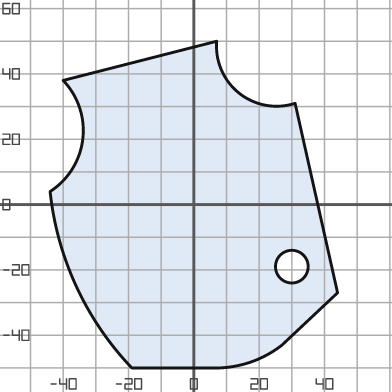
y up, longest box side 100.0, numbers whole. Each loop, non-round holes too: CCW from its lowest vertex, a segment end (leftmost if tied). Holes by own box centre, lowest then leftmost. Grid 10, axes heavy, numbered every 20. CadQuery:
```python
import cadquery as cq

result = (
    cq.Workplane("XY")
    .moveTo(-19.0, -50.0)
    .lineTo(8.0, -50.0)
    .threePointArc((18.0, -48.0), (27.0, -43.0))
    .lineTo(44.0, -27.0)
    .lineTo(31.0, 31.0)
    .threePointArc((14.0, 34.0), (7.0, 50.0))
    .lineTo(-40.0, 38.0)
    .threePointArc((-34.0, 20.0), (-44.0, 4.0))
    .threePointArc((-36.0, -25.0), (-19.0, -50.0))
    .close()
    .moveTo(30.0, -19.0)
    .circle(5.0)
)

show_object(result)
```